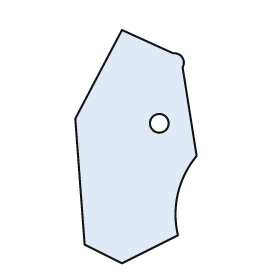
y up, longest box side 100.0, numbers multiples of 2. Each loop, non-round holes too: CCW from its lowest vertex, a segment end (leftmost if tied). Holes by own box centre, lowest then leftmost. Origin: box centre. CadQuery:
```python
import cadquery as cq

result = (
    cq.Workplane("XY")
    .moveTo(-6.0, -50.0)
    .lineTo(18.0, -38.0)
    .threePointArc((18.0, -20.0), (26.0, -4.0))
    .lineTo(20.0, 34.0)
    .threePointArc((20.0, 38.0), (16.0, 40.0))
    .lineTo(-6.0, 50.0)
    .lineTo(-26.0, 12.0)
    .lineTo(-22.0, -42.0)
    .close()
    .moveTo(10.0, 10.0)
    .circle(4.0)
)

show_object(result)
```